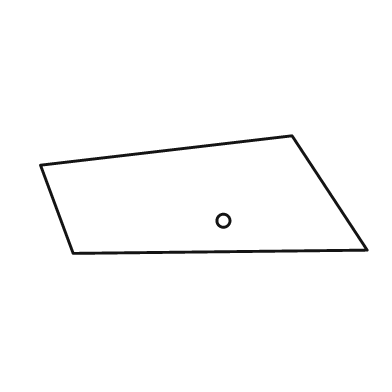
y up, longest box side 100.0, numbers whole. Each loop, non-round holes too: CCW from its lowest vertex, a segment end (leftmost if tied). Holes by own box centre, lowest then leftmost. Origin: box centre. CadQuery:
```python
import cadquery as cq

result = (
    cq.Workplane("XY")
    .moveTo(-40.0, -18.0)
    .lineTo(50.0, -17.0)
    .lineTo(27.0, 18.0)
    .lineTo(-50.0, 9.0)
    .close()
    .moveTo(6.0, -8.0)
    .circle(2.0)
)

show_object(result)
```